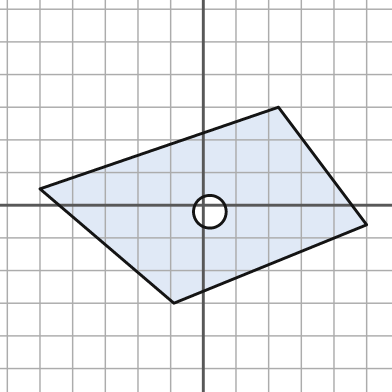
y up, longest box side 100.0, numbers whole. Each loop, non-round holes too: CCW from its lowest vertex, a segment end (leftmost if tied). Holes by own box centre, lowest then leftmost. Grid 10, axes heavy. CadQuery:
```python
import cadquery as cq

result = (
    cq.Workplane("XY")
    .moveTo(-9.0, -30.0)
    .lineTo(50.0, -6.0)
    .lineTo(23.0, 30.0)
    .lineTo(-50.0, 5.0)
    .close()
    .moveTo(2.0, -2.0)
    .circle(5.0)
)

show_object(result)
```